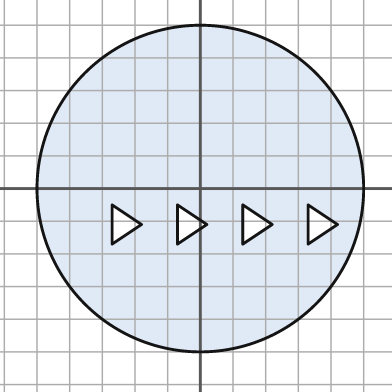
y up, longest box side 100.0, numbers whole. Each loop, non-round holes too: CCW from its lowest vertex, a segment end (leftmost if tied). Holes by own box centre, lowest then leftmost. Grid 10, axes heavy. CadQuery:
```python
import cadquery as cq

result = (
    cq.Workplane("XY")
    .moveTo(0.0, 0.0)
    .circle(50.0)
    .moveTo(-27.0, -17.0)
    .lineTo(-18.0, -11.0)
    .lineTo(-27.0, -5.0)
    .close()
    .moveTo(-7.0, -17.0)
    .lineTo(2.0, -11.0)
    .lineTo(-7.0, -5.0)
    .close()
    .moveTo(13.0, -17.0)
    .lineTo(22.0, -11.0)
    .lineTo(13.0, -5.0)
    .close()
    .moveTo(33.0, -17.0)
    .lineTo(42.0, -11.0)
    .lineTo(33.0, -5.0)
    .close()
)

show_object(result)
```